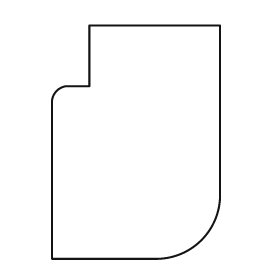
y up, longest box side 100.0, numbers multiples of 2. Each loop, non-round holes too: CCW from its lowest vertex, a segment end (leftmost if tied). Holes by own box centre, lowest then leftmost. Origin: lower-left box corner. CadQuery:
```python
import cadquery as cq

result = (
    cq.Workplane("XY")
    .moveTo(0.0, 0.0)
    .lineTo(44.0, 0.0)
    .threePointArc((64.0, 8.0), (72.0, 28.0))
    .lineTo(72.0, 100.0)
    .lineTo(16.0, 100.0)
    .lineTo(16.0, 74.0)
    .lineTo(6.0, 74.0)
    .threePointArc((2.0, 72.0), (0.0, 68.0))
    .close()
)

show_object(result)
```